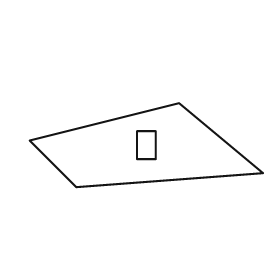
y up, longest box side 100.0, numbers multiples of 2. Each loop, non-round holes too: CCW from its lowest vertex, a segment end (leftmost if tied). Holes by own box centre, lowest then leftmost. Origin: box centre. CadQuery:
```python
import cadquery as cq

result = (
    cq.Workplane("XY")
    .moveTo(-30.0, -18.0)
    .lineTo(50.0, -12.0)
    .lineTo(14.0, 18.0)
    .lineTo(-50.0, 2.0)
    .close()
    .moveTo(-4.0, -6.0)
    .lineTo(4.0, -6.0)
    .lineTo(4.0, 6.0)
    .lineTo(-4.0, 6.0)
    .close()
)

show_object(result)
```